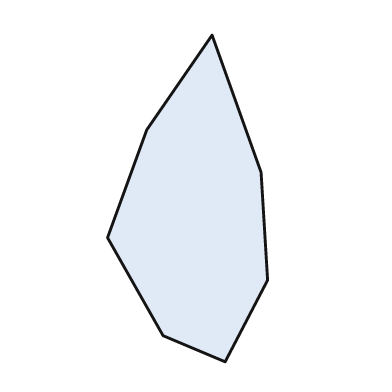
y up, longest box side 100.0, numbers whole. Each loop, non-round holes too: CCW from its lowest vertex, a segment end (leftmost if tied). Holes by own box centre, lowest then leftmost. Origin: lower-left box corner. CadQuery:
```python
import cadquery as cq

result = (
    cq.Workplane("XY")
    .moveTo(36.0, 0.0)
    .lineTo(49.0, 25.0)
    .lineTo(47.0, 58.0)
    .lineTo(32.0, 100.0)
    .lineTo(12.0, 71.0)
    .lineTo(0.0, 38.0)
    .lineTo(17.0, 8.0)
    .close()
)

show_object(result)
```